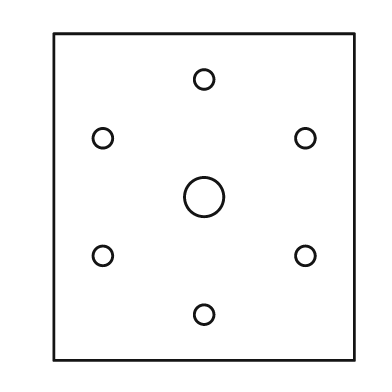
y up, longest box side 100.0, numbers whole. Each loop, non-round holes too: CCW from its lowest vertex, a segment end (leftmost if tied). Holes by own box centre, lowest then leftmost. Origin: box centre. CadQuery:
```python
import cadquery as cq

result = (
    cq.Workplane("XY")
    .moveTo(-46.0, -50.0)
    .lineTo(46.0, -50.0)
    .lineTo(46.0, 50.0)
    .lineTo(-46.0, 50.0)
    .close()
    .moveTo(0.0, -36.0)
    .circle(3.0)
    .moveTo(-31.0, -18.0)
    .circle(3.0)
    .moveTo(31.0, -18.0)
    .circle(3.0)
    .moveTo(0.0, 0.0)
    .circle(6.0)
    .moveTo(-31.0, 18.0)
    .circle(3.0)
    .moveTo(31.0, 18.0)
    .circle(3.0)
    .moveTo(0.0, 36.0)
    .circle(3.0)
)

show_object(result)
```